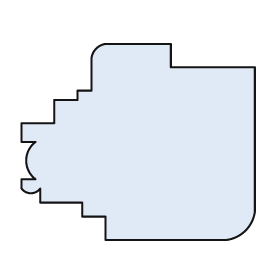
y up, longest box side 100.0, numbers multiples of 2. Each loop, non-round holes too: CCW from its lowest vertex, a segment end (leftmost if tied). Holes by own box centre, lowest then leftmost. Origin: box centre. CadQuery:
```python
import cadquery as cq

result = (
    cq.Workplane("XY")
    .moveTo(-14.0, -42.0)
    .lineTo(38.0, -42.0)
    .threePointArc((46.0, -38.0), (50.0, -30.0))
    .lineTo(50.0, 32.0)
    .lineTo(14.0, 32.0)
    .lineTo(14.0, 42.0)
    .lineTo(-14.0, 42.0)
    .threePointArc((-18.0, 40.0), (-20.0, 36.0))
    .lineTo(-20.0, 22.0)
    .lineTo(-26.0, 22.0)
    .lineTo(-26.0, 18.0)
    .lineTo(-36.0, 18.0)
    .lineTo(-36.0, 8.0)
    .lineTo(-50.0, 8.0)
    .lineTo(-50.0, 0.0)
    .lineTo(-44.0, 0.0)
    .threePointArc((-48.0, -8.0), (-44.0, -16.0))
    .lineTo(-50.0, -16.0)
    .lineTo(-50.0, -20.0)
    .threePointArc((-46.0, -22.0), (-42.0, -20.0))
    .lineTo(-42.0, -26.0)
    .lineTo(-24.0, -26.0)
    .lineTo(-24.0, -32.0)
    .lineTo(-14.0, -32.0)
    .close()
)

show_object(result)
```